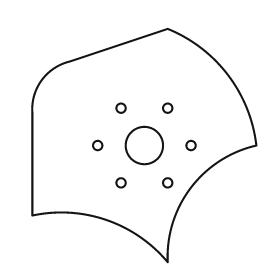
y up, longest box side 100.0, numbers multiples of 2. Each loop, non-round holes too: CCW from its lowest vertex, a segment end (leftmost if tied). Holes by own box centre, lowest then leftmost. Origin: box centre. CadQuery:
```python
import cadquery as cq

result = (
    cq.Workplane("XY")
    .moveTo(10.0, -50.0)
    .threePointArc((20.0, -18.0), (48.0, 0.0))
    .threePointArc((36.0, 30.0), (10.0, 50.0))
    .lineTo(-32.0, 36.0)
    .threePointArc((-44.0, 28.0), (-48.0, 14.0))
    .lineTo(-48.0, -30.0)
    .threePointArc((-16.0, -32.0), (10.0, -50.0))
    .close()
    .moveTo(-10.0, -16.0)
    .circle(2.0)
    .moveTo(10.0, -16.0)
    .circle(2.0)
    .moveTo(-20.0, 0.0)
    .circle(2.0)
    .moveTo(0.0, 0.0)
    .circle(8.0)
    .moveTo(20.0, 0.0)
    .circle(2.0)
    .moveTo(-10.0, 16.0)
    .circle(2.0)
    .moveTo(10.0, 16.0)
    .circle(2.0)
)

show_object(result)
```